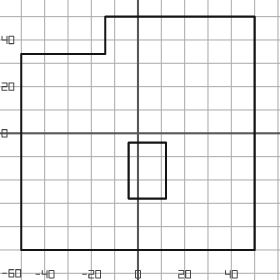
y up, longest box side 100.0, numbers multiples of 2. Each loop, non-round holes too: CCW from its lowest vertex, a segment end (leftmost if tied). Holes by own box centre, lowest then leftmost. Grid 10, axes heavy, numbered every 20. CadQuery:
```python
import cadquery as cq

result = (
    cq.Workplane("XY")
    .moveTo(-50.0, -50.0)
    .lineTo(50.0, -50.0)
    .lineTo(50.0, 50.0)
    .lineTo(-14.0, 50.0)
    .lineTo(-14.0, 34.0)
    .lineTo(-50.0, 34.0)
    .close()
    .moveTo(-4.0, -28.0)
    .lineTo(12.0, -28.0)
    .lineTo(12.0, -4.0)
    .lineTo(-4.0, -4.0)
    .close()
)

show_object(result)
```